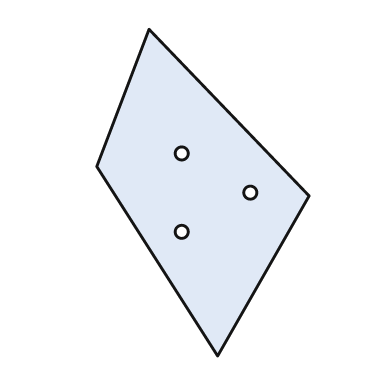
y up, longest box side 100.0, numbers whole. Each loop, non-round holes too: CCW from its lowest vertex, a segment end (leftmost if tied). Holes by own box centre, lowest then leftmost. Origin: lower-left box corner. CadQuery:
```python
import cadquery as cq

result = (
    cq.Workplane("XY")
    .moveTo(37.0, 0.0)
    .lineTo(65.0, 49.0)
    .lineTo(16.0, 100.0)
    .lineTo(0.0, 58.0)
    .close()
    .moveTo(26.0, 38.0)
    .circle(2.0)
    .moveTo(47.0, 50.0)
    .circle(2.0)
    .moveTo(26.0, 62.0)
    .circle(2.0)
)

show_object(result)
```